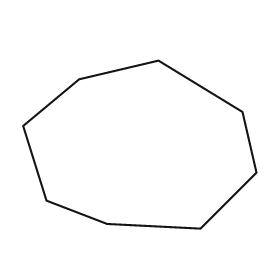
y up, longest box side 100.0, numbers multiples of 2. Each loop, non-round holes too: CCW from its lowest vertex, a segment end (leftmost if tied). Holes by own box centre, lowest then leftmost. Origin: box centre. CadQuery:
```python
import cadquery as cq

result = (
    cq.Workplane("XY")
    .moveTo(26.0, -36.0)
    .lineTo(50.0, -12.0)
    .lineTo(44.0, 14.0)
    .lineTo(8.0, 36.0)
    .lineTo(-26.0, 28.0)
    .lineTo(-50.0, 8.0)
    .lineTo(-40.0, -24.0)
    .lineTo(-14.0, -34.0)
    .close()
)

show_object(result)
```